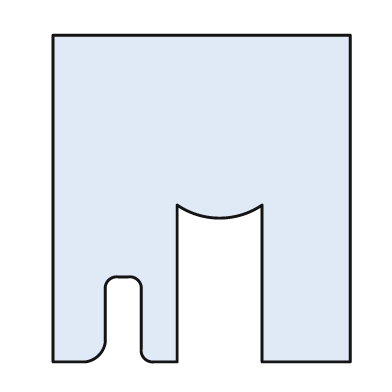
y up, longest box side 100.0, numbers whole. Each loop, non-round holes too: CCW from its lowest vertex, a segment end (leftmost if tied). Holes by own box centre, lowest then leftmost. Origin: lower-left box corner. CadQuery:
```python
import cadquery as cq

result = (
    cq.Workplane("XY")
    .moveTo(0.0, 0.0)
    .lineTo(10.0, 0.0)
    .threePointArc((14.0, 2.0), (16.0, 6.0))
    .lineTo(16.0, 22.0)
    .threePointArc((17.0, 25.0), (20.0, 26.0))
    .lineTo(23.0, 26.0)
    .threePointArc((26.0, 25.0), (27.0, 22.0))
    .lineTo(27.0, 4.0)
    .threePointArc((28.0, 1.0), (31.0, 0.0))
    .lineTo(38.0, 0.0)
    .lineTo(38.0, 48.0)
    .threePointArc((51.0, 44.0), (64.0, 48.0))
    .lineTo(64.0, 0.0)
    .lineTo(91.0, 0.0)
    .lineTo(91.0, 100.0)
    .lineTo(0.0, 100.0)
    .close()
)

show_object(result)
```